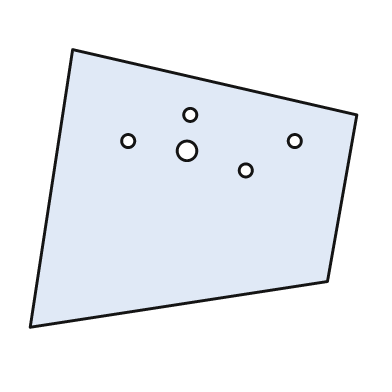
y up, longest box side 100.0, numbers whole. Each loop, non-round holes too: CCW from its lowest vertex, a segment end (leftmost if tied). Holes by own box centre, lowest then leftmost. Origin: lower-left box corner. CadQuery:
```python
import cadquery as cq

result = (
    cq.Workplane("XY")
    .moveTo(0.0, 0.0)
    .lineTo(91.0, 14.0)
    .lineTo(100.0, 65.0)
    .lineTo(13.0, 85.0)
    .close()
    .moveTo(66.0, 48.0)
    .circle(2.0)
    .moveTo(48.0, 54.0)
    .circle(3.0)
    .moveTo(30.0, 57.0)
    .circle(2.0)
    .moveTo(81.0, 57.0)
    .circle(2.0)
    .moveTo(49.0, 65.0)
    .circle(2.0)
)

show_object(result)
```